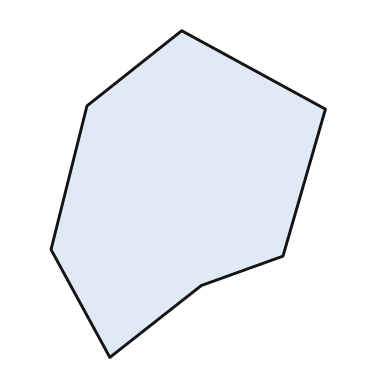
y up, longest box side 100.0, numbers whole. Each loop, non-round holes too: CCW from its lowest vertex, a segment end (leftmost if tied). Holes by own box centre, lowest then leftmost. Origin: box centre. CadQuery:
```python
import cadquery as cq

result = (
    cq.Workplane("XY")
    .moveTo(-24.0, -50.0)
    .lineTo(4.0, -28.0)
    .lineTo(29.0, -19.0)
    .lineTo(42.0, 26.0)
    .lineTo(-2.0, 50.0)
    .lineTo(-31.0, 27.0)
    .lineTo(-42.0, -17.0)
    .close()
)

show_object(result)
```